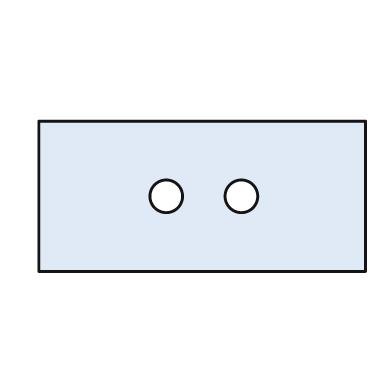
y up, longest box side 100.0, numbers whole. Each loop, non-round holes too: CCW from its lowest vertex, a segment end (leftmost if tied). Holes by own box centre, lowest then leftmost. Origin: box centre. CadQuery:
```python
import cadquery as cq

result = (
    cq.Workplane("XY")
    .moveTo(-50.0, -23.0)
    .lineTo(50.0, -23.0)
    .lineTo(50.0, 23.0)
    .lineTo(-50.0, 23.0)
    .close()
    .moveTo(-11.0, 0.0)
    .circle(5.0)
    .moveTo(12.0, 0.0)
    .circle(5.0)
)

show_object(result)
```